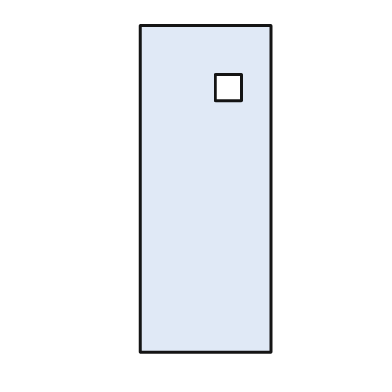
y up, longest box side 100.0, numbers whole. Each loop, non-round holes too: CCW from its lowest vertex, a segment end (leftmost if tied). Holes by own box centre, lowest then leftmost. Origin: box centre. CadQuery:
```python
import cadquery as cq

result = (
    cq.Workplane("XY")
    .moveTo(-20.0, -50.0)
    .lineTo(20.0, -50.0)
    .lineTo(20.0, 50.0)
    .lineTo(-20.0, 50.0)
    .close()
    .moveTo(3.0, 27.0)
    .lineTo(11.0, 27.0)
    .lineTo(11.0, 35.0)
    .lineTo(3.0, 35.0)
    .close()
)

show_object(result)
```